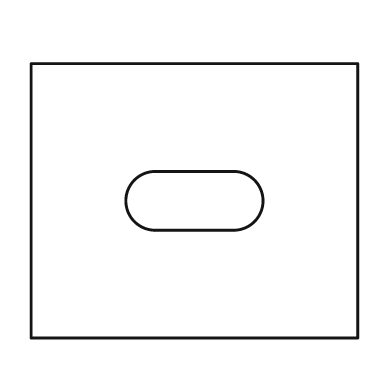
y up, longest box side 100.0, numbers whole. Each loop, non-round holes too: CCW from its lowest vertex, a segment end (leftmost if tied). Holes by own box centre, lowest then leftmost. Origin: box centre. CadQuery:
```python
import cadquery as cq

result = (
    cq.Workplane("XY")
    .moveTo(-50.0, -42.0)
    .lineTo(50.0, -42.0)
    .lineTo(50.0, 42.0)
    .lineTo(-50.0, 42.0)
    .close()
    .moveTo(-12.0, -9.0)
    .lineTo(12.0, -9.0)
    .threePointArc((21.0, 0.0), (12.0, 9.0))
    .lineTo(-12.0, 9.0)
    .threePointArc((-21.0, 0.0), (-12.0, -9.0))
    .close()
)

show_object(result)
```